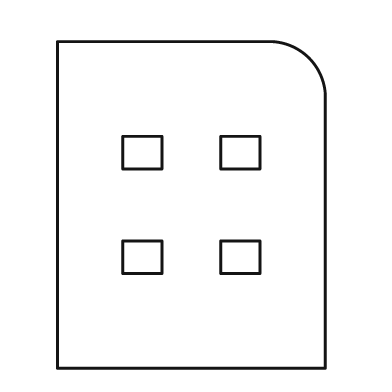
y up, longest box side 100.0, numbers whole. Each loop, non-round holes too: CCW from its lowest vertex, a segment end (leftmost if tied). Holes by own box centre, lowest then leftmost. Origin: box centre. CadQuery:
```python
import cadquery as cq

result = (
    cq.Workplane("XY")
    .moveTo(-41.0, -50.0)
    .lineTo(41.0, -50.0)
    .lineTo(41.0, 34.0)
    .threePointArc((36.0, 45.0), (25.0, 50.0))
    .lineTo(-41.0, 50.0)
    .close()
    .moveTo(-21.0, -21.0)
    .lineTo(-9.0, -21.0)
    .lineTo(-9.0, -11.0)
    .lineTo(-21.0, -11.0)
    .close()
    .moveTo(9.0, -21.0)
    .lineTo(21.0, -21.0)
    .lineTo(21.0, -11.0)
    .lineTo(9.0, -11.0)
    .close()
    .moveTo(-21.0, 11.0)
    .lineTo(-9.0, 11.0)
    .lineTo(-9.0, 21.0)
    .lineTo(-21.0, 21.0)
    .close()
    .moveTo(9.0, 11.0)
    .lineTo(21.0, 11.0)
    .lineTo(21.0, 21.0)
    .lineTo(9.0, 21.0)
    .close()
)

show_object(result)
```